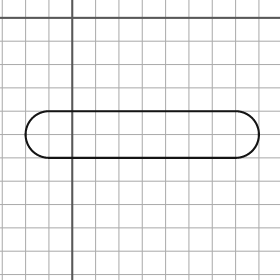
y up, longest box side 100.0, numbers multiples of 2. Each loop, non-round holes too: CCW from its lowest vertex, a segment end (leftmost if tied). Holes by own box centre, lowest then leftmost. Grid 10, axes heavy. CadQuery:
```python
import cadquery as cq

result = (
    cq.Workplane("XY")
    .moveTo(-10.0, -60.0)
    .lineTo(70.0, -60.0)
    .threePointArc((80.0, -50.0), (70.0, -40.0))
    .lineTo(-10.0, -40.0)
    .threePointArc((-20.0, -50.0), (-10.0, -60.0))
    .close()
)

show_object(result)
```